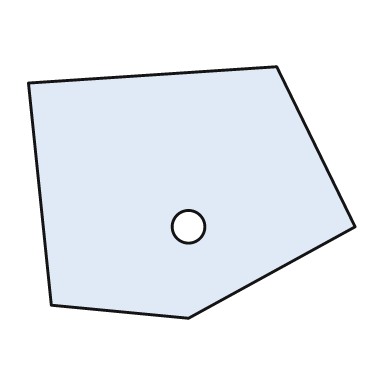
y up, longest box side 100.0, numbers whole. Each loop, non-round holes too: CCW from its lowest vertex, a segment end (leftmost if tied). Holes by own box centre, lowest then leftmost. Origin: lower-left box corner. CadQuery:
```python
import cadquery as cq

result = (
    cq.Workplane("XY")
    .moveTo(49.0, 0.0)
    .lineTo(100.0, 28.0)
    .lineTo(76.0, 77.0)
    .lineTo(0.0, 72.0)
    .lineTo(7.0, 4.0)
    .close()
    .moveTo(49.0, 28.0)
    .circle(5.0)
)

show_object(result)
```